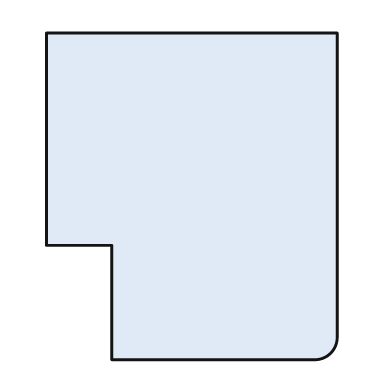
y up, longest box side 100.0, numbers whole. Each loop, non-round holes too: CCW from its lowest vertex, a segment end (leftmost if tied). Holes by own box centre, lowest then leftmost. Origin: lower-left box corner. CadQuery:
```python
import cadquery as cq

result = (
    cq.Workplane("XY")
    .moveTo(20.0, 0.0)
    .lineTo(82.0, 0.0)
    .threePointArc((87.0, 2.0), (89.0, 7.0))
    .lineTo(89.0, 100.0)
    .lineTo(0.0, 100.0)
    .lineTo(0.0, 35.0)
    .lineTo(20.0, 35.0)
    .close()
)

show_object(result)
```